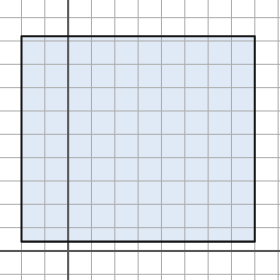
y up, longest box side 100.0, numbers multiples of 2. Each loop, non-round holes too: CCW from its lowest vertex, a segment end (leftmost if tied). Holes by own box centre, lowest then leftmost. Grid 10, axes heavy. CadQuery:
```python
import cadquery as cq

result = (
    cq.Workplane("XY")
    .moveTo(-20.0, 4.0)
    .lineTo(80.0, 4.0)
    .lineTo(80.0, 92.0)
    .lineTo(-20.0, 92.0)
    .close()
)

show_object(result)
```